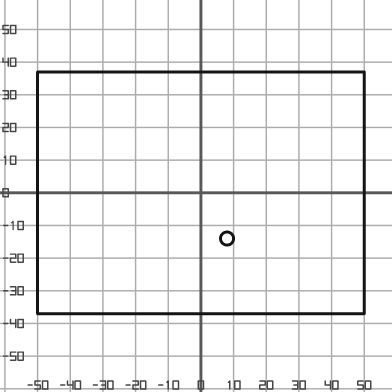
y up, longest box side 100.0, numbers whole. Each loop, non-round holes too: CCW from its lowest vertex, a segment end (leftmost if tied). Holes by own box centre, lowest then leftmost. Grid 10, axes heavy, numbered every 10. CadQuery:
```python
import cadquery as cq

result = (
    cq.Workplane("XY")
    .moveTo(-50.0, -37.0)
    .lineTo(50.0, -37.0)
    .lineTo(50.0, 37.0)
    .lineTo(-50.0, 37.0)
    .close()
    .moveTo(8.0, -14.0)
    .circle(2.0)
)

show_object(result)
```